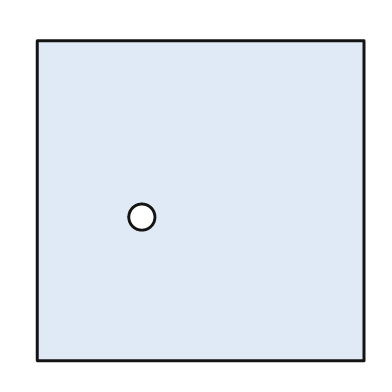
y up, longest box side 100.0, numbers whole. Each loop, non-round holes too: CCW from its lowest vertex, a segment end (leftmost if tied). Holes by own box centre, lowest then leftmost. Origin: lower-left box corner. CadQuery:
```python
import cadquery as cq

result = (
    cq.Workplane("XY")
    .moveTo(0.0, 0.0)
    .lineTo(100.0, 0.0)
    .lineTo(100.0, 98.0)
    .lineTo(0.0, 98.0)
    .close()
    .moveTo(32.0, 44.0)
    .circle(4.0)
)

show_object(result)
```